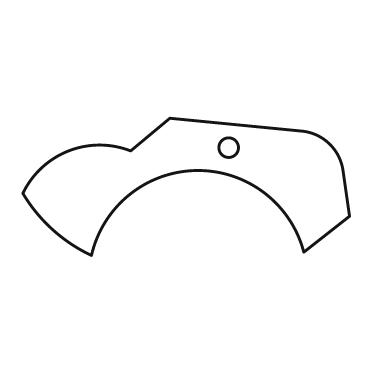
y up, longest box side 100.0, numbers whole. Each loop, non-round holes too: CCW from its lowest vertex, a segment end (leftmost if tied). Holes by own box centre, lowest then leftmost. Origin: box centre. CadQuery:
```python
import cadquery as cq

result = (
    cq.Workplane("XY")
    .moveTo(-29.0, -21.0)
    .threePointArc((3.0, 5.0), (36.0, -20.0))
    .lineTo(50.0, -9.0)
    .lineTo(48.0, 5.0)
    .threePointArc((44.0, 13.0), (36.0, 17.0))
    .lineTo(-5.0, 21.0)
    .lineTo(-17.0, 11.0)
    .threePointArc((-36.0, 11.0), (-50.0, -2.0))
    .threePointArc((-41.0, -13.0), (-29.0, -21.0))
    .close()
    .moveTo(13.0, 12.0)
    .circle(3.0)
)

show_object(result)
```